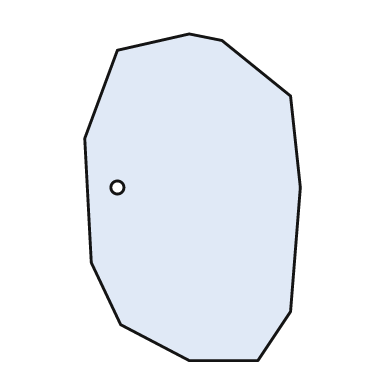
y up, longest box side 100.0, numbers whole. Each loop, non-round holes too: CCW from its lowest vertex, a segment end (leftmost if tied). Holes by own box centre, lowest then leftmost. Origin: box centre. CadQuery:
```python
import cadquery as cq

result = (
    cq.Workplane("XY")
    .moveTo(-1.0, -50.0)
    .lineTo(20.0, -50.0)
    .lineTo(30.0, -35.0)
    .lineTo(33.0, 3.0)
    .lineTo(30.0, 31.0)
    .lineTo(9.0, 48.0)
    .lineTo(-1.0, 50.0)
    .lineTo(-23.0, 45.0)
    .lineTo(-33.0, 18.0)
    .lineTo(-31.0, -20.0)
    .lineTo(-22.0, -39.0)
    .close()
    .moveTo(-23.0, 3.0)
    .circle(2.0)
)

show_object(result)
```